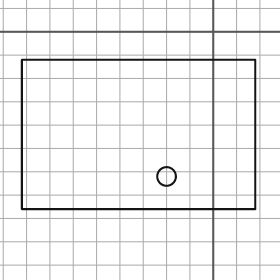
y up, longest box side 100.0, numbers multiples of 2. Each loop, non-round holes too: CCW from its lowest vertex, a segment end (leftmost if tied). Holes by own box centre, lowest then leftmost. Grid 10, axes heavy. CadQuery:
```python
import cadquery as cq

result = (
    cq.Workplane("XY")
    .moveTo(-82.0, -76.0)
    .lineTo(18.0, -76.0)
    .lineTo(18.0, -12.0)
    .lineTo(-82.0, -12.0)
    .close()
    .moveTo(-20.0, -62.0)
    .circle(4.0)
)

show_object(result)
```